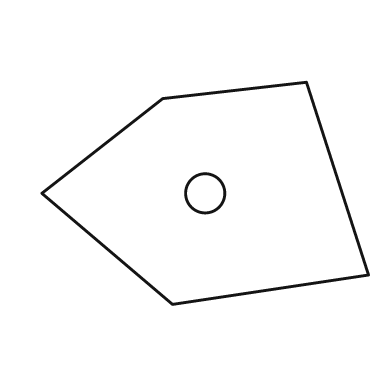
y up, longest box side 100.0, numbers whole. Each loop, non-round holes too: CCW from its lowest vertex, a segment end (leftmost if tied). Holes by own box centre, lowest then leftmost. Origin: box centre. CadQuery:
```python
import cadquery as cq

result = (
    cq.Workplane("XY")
    .moveTo(-10.0, -34.0)
    .lineTo(50.0, -25.0)
    .lineTo(31.0, 34.0)
    .lineTo(-13.0, 29.0)
    .lineTo(-50.0, 0.0)
    .close()
    .moveTo(0.0, 0.0)
    .circle(6.0)
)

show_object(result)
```